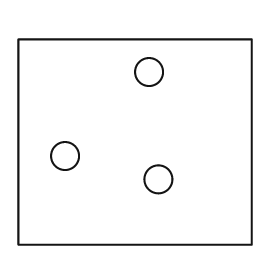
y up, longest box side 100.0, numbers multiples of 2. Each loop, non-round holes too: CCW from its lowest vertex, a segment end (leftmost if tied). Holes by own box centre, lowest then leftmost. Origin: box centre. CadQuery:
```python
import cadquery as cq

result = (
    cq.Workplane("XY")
    .moveTo(-50.0, -44.0)
    .lineTo(50.0, -44.0)
    .lineTo(50.0, 44.0)
    .lineTo(-50.0, 44.0)
    .close()
    .moveTo(10.0, -16.0)
    .circle(6.0)
    .moveTo(-30.0, -6.0)
    .circle(6.0)
    .moveTo(6.0, 30.0)
    .circle(6.0)
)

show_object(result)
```